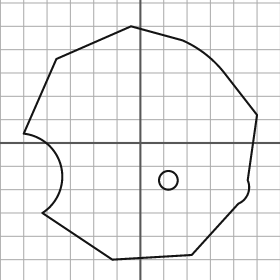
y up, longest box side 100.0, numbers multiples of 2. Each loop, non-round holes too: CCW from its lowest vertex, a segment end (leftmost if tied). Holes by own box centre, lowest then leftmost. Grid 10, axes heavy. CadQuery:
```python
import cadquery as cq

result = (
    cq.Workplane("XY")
    .moveTo(-12.0, -50.0)
    .lineTo(22.0, -48.0)
    .lineTo(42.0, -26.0)
    .threePointArc((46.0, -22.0), (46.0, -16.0))
    .lineTo(50.0, 12.0)
    .lineTo(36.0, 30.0)
    .threePointArc((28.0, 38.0), (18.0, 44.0))
    .lineTo(-4.0, 50.0)
    .lineTo(-36.0, 36.0)
    .lineTo(-50.0, 4.0)
    .threePointArc((-34.0, -10.0), (-42.0, -30.0))
    .close()
    .moveTo(12.0, -16.0)
    .circle(4.0)
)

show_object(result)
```